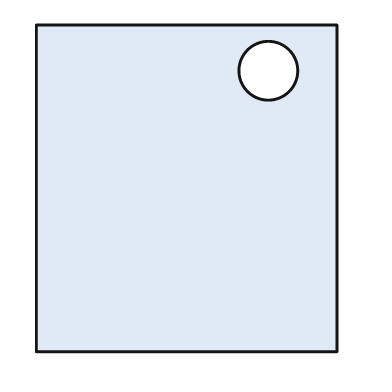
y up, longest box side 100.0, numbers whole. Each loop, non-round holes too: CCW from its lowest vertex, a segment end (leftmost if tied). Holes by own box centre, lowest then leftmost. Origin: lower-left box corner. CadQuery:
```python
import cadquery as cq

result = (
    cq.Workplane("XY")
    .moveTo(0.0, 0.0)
    .lineTo(92.0, 0.0)
    .lineTo(92.0, 100.0)
    .lineTo(0.0, 100.0)
    .close()
    .moveTo(71.0, 86.0)
    .circle(9.0)
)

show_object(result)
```